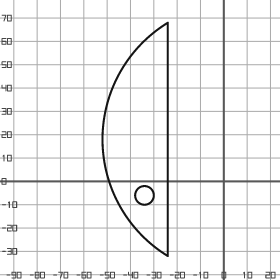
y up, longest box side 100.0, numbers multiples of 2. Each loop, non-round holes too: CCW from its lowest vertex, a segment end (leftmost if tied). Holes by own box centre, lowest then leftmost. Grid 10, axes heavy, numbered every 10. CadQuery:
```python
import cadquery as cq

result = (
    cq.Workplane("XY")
    .moveTo(-24.0, -32.0)
    .lineTo(-24.0, 68.0)
    .threePointArc((-52.0, 18.0), (-24.0, -32.0))
    .close()
    .moveTo(-34.0, -6.0)
    .circle(4.0)
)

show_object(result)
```